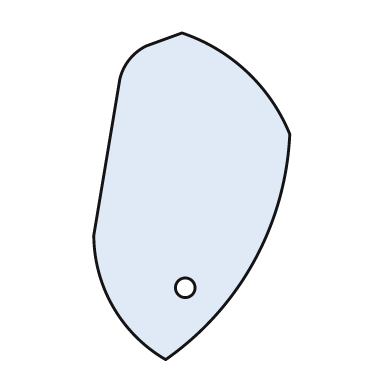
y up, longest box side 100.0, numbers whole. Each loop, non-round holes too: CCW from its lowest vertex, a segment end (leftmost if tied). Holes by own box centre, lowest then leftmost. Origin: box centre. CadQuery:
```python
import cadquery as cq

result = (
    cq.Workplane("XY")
    .moveTo(-8.0, -50.0)
    .threePointArc((19.0, -20.0), (30.0, 19.0))
    .threePointArc((17.0, 38.0), (-3.0, 50.0))
    .lineTo(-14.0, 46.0)
    .threePointArc((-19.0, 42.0), (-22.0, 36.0))
    .lineTo(-30.0, -12.0)
    .threePointArc((-24.0, -34.0), (-8.0, -50.0))
    .close()
    .moveTo(-2.0, -28.0)
    .circle(3.0)
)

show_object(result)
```